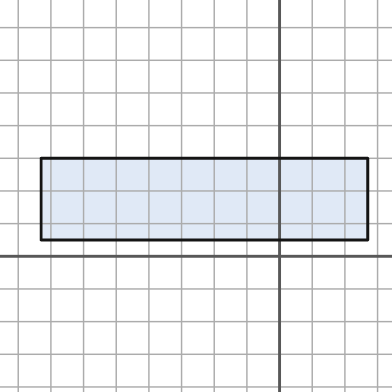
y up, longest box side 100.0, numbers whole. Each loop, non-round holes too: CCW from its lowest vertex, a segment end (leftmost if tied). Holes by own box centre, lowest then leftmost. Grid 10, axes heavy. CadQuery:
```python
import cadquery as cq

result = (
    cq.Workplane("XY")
    .moveTo(-73.0, 5.0)
    .lineTo(27.0, 5.0)
    .lineTo(27.0, 30.0)
    .lineTo(-73.0, 30.0)
    .close()
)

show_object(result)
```